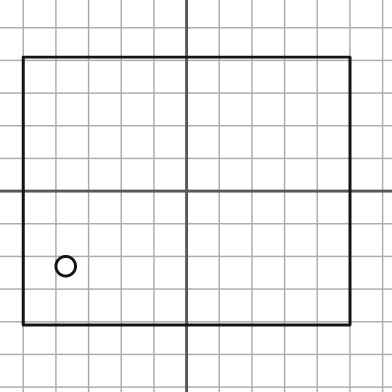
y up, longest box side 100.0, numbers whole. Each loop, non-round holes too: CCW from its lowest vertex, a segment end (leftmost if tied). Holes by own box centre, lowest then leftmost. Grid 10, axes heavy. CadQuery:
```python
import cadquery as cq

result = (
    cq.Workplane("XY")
    .moveTo(-50.0, -41.0)
    .lineTo(50.0, -41.0)
    .lineTo(50.0, 41.0)
    .lineTo(-50.0, 41.0)
    .close()
    .moveTo(-37.0, -23.0)
    .circle(3.0)
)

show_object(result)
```